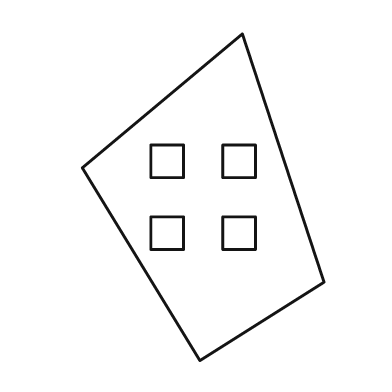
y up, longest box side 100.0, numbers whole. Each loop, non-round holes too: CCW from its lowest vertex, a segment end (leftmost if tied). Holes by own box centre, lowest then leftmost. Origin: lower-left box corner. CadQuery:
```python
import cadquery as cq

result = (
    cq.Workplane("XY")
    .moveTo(36.0, 0.0)
    .lineTo(74.0, 24.0)
    .lineTo(49.0, 100.0)
    .lineTo(0.0, 59.0)
    .close()
    .moveTo(21.0, 34.0)
    .lineTo(31.0, 34.0)
    .lineTo(31.0, 44.0)
    .lineTo(21.0, 44.0)
    .close()
    .moveTo(43.0, 34.0)
    .lineTo(53.0, 34.0)
    .lineTo(53.0, 44.0)
    .lineTo(43.0, 44.0)
    .close()
    .moveTo(21.0, 56.0)
    .lineTo(31.0, 56.0)
    .lineTo(31.0, 66.0)
    .lineTo(21.0, 66.0)
    .close()
    .moveTo(43.0, 56.0)
    .lineTo(53.0, 56.0)
    .lineTo(53.0, 66.0)
    .lineTo(43.0, 66.0)
    .close()
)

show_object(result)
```